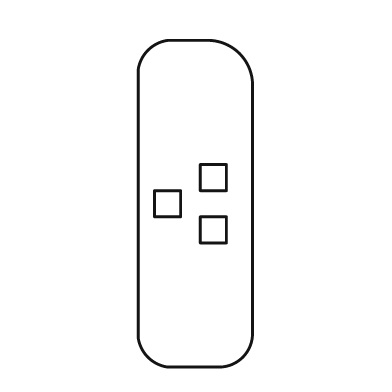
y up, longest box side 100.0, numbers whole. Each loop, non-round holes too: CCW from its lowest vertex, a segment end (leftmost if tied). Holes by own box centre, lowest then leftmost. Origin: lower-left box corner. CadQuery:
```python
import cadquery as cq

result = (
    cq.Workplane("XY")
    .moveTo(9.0, 0.0)
    .lineTo(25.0, 0.0)
    .threePointArc((32.0, 3.0), (35.0, 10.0))
    .lineTo(35.0, 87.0)
    .threePointArc((31.0, 96.0), (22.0, 100.0))
    .lineTo(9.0, 100.0)
    .threePointArc((3.0, 97.0), (0.0, 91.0))
    .lineTo(0.0, 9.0)
    .threePointArc((3.0, 3.0), (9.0, 0.0))
    .close()
    .moveTo(19.0, 38.0)
    .lineTo(27.0, 38.0)
    .lineTo(27.0, 46.0)
    .lineTo(19.0, 46.0)
    .close()
    .moveTo(5.0, 46.0)
    .lineTo(13.0, 46.0)
    .lineTo(13.0, 54.0)
    .lineTo(5.0, 54.0)
    .close()
    .moveTo(19.0, 54.0)
    .lineTo(27.0, 54.0)
    .lineTo(27.0, 62.0)
    .lineTo(19.0, 62.0)
    .close()
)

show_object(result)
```